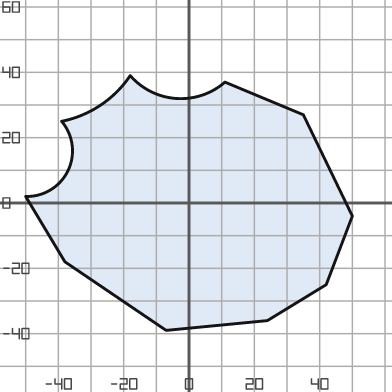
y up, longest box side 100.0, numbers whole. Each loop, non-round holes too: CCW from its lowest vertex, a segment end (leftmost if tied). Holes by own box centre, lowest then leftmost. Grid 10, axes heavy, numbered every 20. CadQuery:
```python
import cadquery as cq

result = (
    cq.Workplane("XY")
    .moveTo(-7.0, -39.0)
    .lineTo(24.0, -36.0)
    .lineTo(42.0, -25.0)
    .lineTo(50.0, -4.0)
    .lineTo(35.0, 27.0)
    .lineTo(11.0, 37.0)
    .threePointArc((-4.0, 32.0), (-18.0, 39.0))
    .threePointArc((-27.0, 30.0), (-39.0, 25.0))
    .threePointArc((-37.0, 10.0), (-50.0, 2.0))
    .lineTo(-38.0, -18.0)
    .close()
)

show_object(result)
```